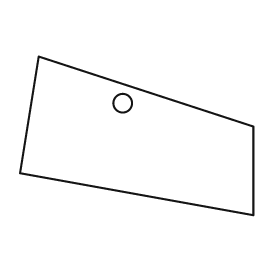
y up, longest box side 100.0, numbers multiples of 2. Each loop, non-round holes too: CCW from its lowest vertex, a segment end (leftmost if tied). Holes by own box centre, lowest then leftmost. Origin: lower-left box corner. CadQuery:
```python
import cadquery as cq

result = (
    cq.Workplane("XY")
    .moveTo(100.0, 0.0)
    .lineTo(100.0, 38.0)
    .lineTo(8.0, 68.0)
    .lineTo(0.0, 18.0)
    .close()
    .moveTo(44.0, 48.0)
    .circle(4.0)
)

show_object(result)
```